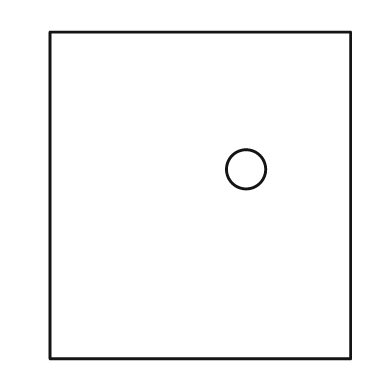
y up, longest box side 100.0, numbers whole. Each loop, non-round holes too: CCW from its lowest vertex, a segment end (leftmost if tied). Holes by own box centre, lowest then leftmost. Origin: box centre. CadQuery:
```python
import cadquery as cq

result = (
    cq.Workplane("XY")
    .moveTo(-46.0, -50.0)
    .lineTo(46.0, -50.0)
    .lineTo(46.0, 50.0)
    .lineTo(-46.0, 50.0)
    .close()
    .moveTo(14.0, 8.0)
    .circle(6.0)
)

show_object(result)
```